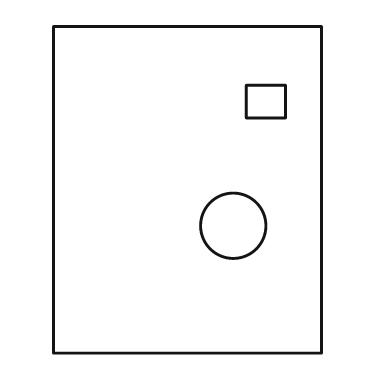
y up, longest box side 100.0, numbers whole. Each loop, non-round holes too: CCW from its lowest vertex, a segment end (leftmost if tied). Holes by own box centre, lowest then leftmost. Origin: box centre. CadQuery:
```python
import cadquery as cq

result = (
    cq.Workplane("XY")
    .moveTo(-41.0, -50.0)
    .lineTo(41.0, -50.0)
    .lineTo(41.0, 50.0)
    .lineTo(-41.0, 50.0)
    .close()
    .moveTo(14.0, -11.0)
    .circle(10.0)
    .moveTo(18.0, 22.0)
    .lineTo(30.0, 22.0)
    .lineTo(30.0, 32.0)
    .lineTo(18.0, 32.0)
    .close()
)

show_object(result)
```